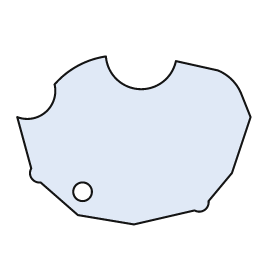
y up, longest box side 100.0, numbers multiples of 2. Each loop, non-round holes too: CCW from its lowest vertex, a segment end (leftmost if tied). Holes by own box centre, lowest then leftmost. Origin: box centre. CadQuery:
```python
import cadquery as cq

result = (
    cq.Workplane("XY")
    .moveTo(0.0, -36.0)
    .lineTo(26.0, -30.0)
    .threePointArc((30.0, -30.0), (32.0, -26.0))
    .lineTo(42.0, -14.0)
    .lineTo(50.0, 10.0)
    .lineTo(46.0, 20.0)
    .threePointArc((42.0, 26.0), (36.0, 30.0))
    .lineTo(18.0, 34.0)
    .threePointArc((2.0, 22.0), (-12.0, 36.0))
    .threePointArc((-24.0, 32.0), (-34.0, 24.0))
    .threePointArc((-38.0, 12.0), (-50.0, 10.0))
    .lineTo(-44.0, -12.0)
    .threePointArc((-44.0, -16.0), (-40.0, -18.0))
    .lineTo(-24.0, -32.0)
    .close()
    .moveTo(-22.0, -22.0)
    .circle(4.0)
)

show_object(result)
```